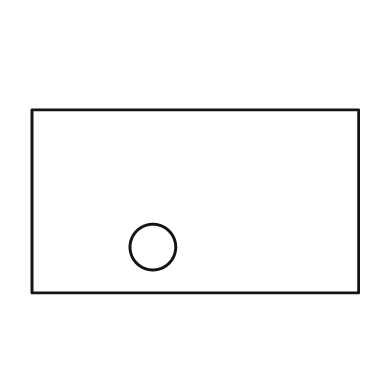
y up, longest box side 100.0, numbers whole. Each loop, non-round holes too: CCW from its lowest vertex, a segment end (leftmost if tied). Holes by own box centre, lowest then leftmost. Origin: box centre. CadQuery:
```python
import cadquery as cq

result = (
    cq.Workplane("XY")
    .moveTo(-50.0, -28.0)
    .lineTo(50.0, -28.0)
    .lineTo(50.0, 28.0)
    .lineTo(-50.0, 28.0)
    .close()
    .moveTo(-13.0, -14.0)
    .circle(7.0)
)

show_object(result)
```